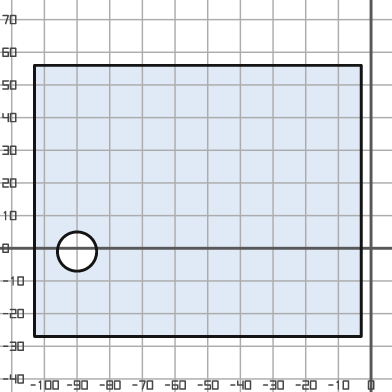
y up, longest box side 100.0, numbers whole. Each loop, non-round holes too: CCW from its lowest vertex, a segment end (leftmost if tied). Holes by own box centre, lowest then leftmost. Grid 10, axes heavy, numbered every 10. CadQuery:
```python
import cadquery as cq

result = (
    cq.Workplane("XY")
    .moveTo(-103.0, -27.0)
    .lineTo(-3.0, -27.0)
    .lineTo(-3.0, 56.0)
    .lineTo(-103.0, 56.0)
    .close()
    .moveTo(-90.0, -1.0)
    .circle(6.0)
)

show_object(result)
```